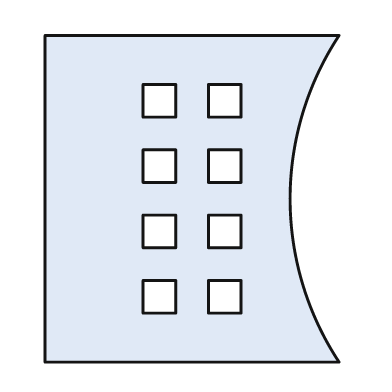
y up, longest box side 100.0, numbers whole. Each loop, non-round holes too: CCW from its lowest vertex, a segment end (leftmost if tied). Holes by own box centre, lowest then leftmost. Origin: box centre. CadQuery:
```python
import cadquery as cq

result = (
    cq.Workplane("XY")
    .moveTo(-45.0, -50.0)
    .lineTo(45.0, -50.0)
    .threePointArc((30.0, 0.0), (45.0, 50.0))
    .lineTo(-45.0, 50.0)
    .close()
    .moveTo(-15.0, -35.0)
    .lineTo(-5.0, -35.0)
    .lineTo(-5.0, -25.0)
    .lineTo(-15.0, -25.0)
    .close()
    .moveTo(5.0, -35.0)
    .lineTo(15.0, -35.0)
    .lineTo(15.0, -25.0)
    .lineTo(5.0, -25.0)
    .close()
    .moveTo(-15.0, -15.0)
    .lineTo(-5.0, -15.0)
    .lineTo(-5.0, -5.0)
    .lineTo(-15.0, -5.0)
    .close()
    .moveTo(5.0, -15.0)
    .lineTo(15.0, -15.0)
    .lineTo(15.0, -5.0)
    .lineTo(5.0, -5.0)
    .close()
    .moveTo(-15.0, 5.0)
    .lineTo(-5.0, 5.0)
    .lineTo(-5.0, 15.0)
    .lineTo(-15.0, 15.0)
    .close()
    .moveTo(5.0, 5.0)
    .lineTo(15.0, 5.0)
    .lineTo(15.0, 15.0)
    .lineTo(5.0, 15.0)
    .close()
    .moveTo(-15.0, 25.0)
    .lineTo(-5.0, 25.0)
    .lineTo(-5.0, 35.0)
    .lineTo(-15.0, 35.0)
    .close()
    .moveTo(5.0, 25.0)
    .lineTo(15.0, 25.0)
    .lineTo(15.0, 35.0)
    .lineTo(5.0, 35.0)
    .close()
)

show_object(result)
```